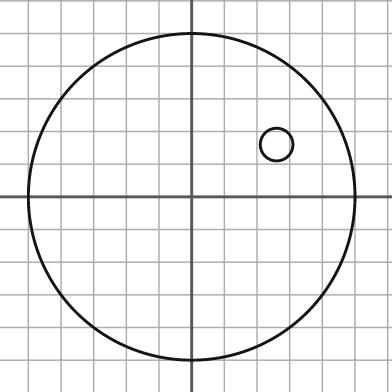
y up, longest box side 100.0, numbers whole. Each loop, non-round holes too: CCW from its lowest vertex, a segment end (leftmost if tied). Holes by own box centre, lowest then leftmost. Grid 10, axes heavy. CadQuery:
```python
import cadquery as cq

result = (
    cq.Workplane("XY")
    .moveTo(0.0, 0.0)
    .circle(50.0)
    .moveTo(26.0, 16.0)
    .circle(5.0)
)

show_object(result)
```